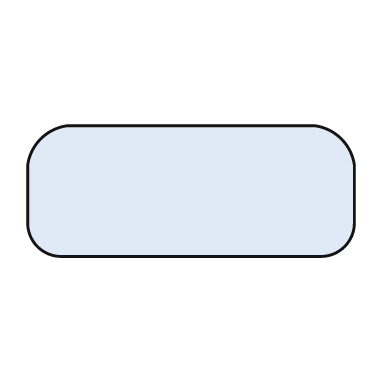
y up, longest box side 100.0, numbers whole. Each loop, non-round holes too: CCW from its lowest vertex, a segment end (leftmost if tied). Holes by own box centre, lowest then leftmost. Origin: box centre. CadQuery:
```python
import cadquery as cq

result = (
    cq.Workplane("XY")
    .moveTo(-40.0, -20.0)
    .lineTo(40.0, -20.0)
    .threePointArc((47.0, -17.0), (50.0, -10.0))
    .lineTo(50.0, 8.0)
    .threePointArc((46.0, 16.0), (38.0, 20.0))
    .lineTo(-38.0, 20.0)
    .threePointArc((-46.0, 16.0), (-50.0, 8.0))
    .lineTo(-50.0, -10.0)
    .threePointArc((-47.0, -17.0), (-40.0, -20.0))
    .close()
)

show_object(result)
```